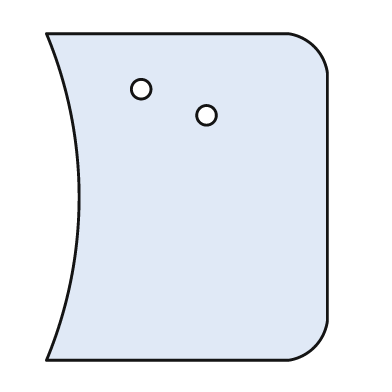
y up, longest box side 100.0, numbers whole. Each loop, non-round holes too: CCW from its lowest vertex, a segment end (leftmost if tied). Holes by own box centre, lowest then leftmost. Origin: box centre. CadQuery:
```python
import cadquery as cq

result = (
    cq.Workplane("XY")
    .moveTo(-43.0, -50.0)
    .lineTo(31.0, -50.0)
    .threePointArc((39.0, -46.0), (43.0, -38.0))
    .lineTo(43.0, 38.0)
    .threePointArc((39.0, 46.0), (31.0, 50.0))
    .lineTo(-43.0, 50.0)
    .threePointArc((-33.0, 0.0), (-43.0, -50.0))
    .close()
    .moveTo(6.0, 25.0)
    .circle(3.0)
    .moveTo(-14.0, 33.0)
    .circle(3.0)
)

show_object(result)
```